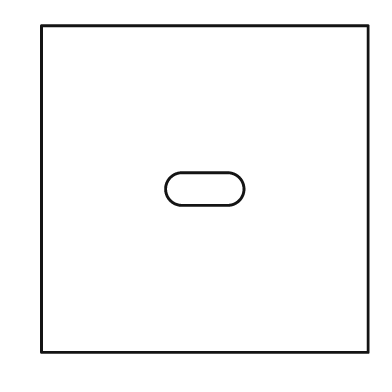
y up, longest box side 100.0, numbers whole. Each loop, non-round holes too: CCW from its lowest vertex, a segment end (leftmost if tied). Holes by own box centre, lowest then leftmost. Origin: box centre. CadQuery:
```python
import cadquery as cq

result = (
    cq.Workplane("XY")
    .moveTo(-50.0, -50.0)
    .lineTo(50.0, -50.0)
    .lineTo(50.0, 50.0)
    .lineTo(-50.0, 50.0)
    .close()
    .moveTo(-7.0, -5.0)
    .lineTo(7.0, -5.0)
    .threePointArc((12.0, 0.0), (7.0, 5.0))
    .lineTo(-7.0, 5.0)
    .threePointArc((-12.0, 0.0), (-7.0, -5.0))
    .close()
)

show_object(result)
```